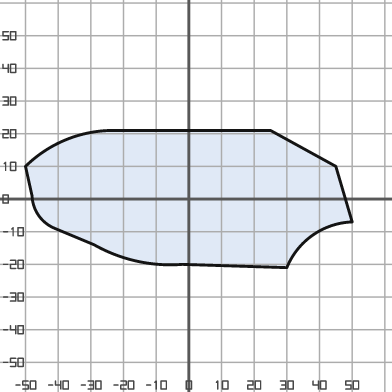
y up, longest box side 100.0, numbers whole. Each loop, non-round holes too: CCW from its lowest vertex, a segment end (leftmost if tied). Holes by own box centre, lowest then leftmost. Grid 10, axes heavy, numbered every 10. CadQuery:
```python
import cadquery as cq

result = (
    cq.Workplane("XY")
    .moveTo(30.0, -21.0)
    .threePointArc((38.0, -11.0), (50.0, -7.0))
    .lineTo(45.0, 10.0)
    .lineTo(25.0, 21.0)
    .lineTo(-24.0, 21.0)
    .threePointArc((-38.0, 18.0), (-50.0, 10.0))
    .lineTo(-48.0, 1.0)
    .threePointArc((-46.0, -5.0), (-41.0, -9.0))
    .lineTo(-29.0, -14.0)
    .threePointArc((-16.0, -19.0), (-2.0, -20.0))
    .close()
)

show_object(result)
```